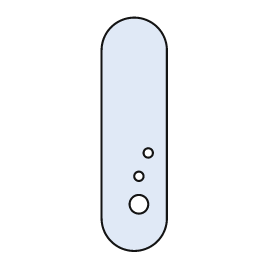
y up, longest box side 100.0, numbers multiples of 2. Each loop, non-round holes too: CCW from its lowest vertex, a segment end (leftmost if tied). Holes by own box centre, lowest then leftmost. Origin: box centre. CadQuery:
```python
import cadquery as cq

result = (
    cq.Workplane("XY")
    .moveTo(-14.0, -36.0)
    .threePointArc((0.0, -50.0), (14.0, -36.0))
    .lineTo(14.0, 36.0)
    .threePointArc((0.0, 50.0), (-14.0, 36.0))
    .close()
    .moveTo(2.0, -30.0)
    .circle(4.0)
    .moveTo(2.0, -18.0)
    .circle(2.0)
    .moveTo(6.0, -8.0)
    .circle(2.0)
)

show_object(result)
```